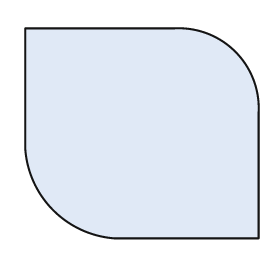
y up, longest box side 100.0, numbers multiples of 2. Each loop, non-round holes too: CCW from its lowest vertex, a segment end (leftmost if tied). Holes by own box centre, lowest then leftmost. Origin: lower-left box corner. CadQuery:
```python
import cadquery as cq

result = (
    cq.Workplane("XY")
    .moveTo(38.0, 0.0)
    .lineTo(100.0, 0.0)
    .lineTo(100.0, 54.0)
    .threePointArc((90.0, 80.0), (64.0, 90.0))
    .lineTo(0.0, 90.0)
    .lineTo(0.0, 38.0)
    .threePointArc((12.0, 12.0), (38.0, 0.0))
    .close()
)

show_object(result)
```